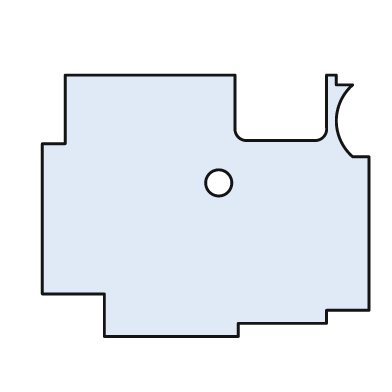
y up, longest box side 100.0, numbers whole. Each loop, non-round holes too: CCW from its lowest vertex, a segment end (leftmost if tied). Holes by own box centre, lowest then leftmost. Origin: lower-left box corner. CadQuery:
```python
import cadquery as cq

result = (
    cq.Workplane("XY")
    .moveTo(19.0, 0.0)
    .lineTo(60.0, 0.0)
    .lineTo(60.0, 4.0)
    .lineTo(87.0, 4.0)
    .lineTo(87.0, 8.0)
    .lineTo(100.0, 8.0)
    .lineTo(100.0, 55.0)
    .lineTo(95.0, 55.0)
    .threePointArc((90.0, 66.0), (95.0, 77.0))
    .lineTo(90.0, 77.0)
    .lineTo(90.0, 80.0)
    .lineTo(87.0, 80.0)
    .lineTo(87.0, 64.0)
    .threePointArc((86.0, 61.0), (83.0, 60.0))
    .lineTo(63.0, 60.0)
    .threePointArc((60.0, 61.0), (59.0, 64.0))
    .lineTo(59.0, 80.0)
    .lineTo(7.0, 80.0)
    .lineTo(7.0, 59.0)
    .lineTo(0.0, 59.0)
    .lineTo(0.0, 13.0)
    .lineTo(19.0, 13.0)
    .close()
    .moveTo(54.0, 47.0)
    .circle(4.0)
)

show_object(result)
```